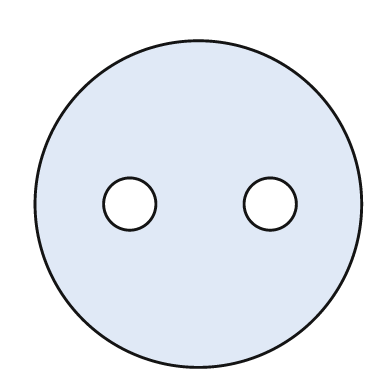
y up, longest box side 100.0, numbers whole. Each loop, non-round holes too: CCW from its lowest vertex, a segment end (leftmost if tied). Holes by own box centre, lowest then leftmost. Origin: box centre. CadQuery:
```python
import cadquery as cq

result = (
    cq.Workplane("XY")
    .moveTo(0.0, 0.0)
    .circle(50.0)
    .moveTo(-21.0, 0.0)
    .circle(8.0)
    .moveTo(22.0, 0.0)
    .circle(8.0)
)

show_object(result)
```